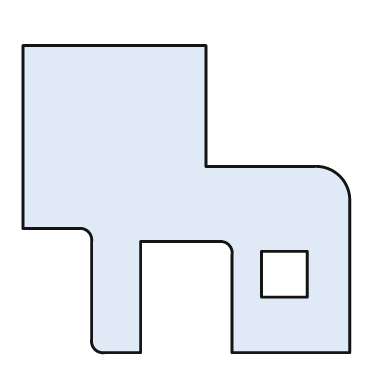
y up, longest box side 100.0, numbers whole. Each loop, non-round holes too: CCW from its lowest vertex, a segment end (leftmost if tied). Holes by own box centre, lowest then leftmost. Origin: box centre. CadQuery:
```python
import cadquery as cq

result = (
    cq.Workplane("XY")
    .moveTo(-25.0, -47.0)
    .lineTo(-14.0, -47.0)
    .lineTo(-14.0, -13.0)
    .lineTo(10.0, -13.0)
    .threePointArc((13.0, -14.0), (14.0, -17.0))
    .lineTo(14.0, -47.0)
    .lineTo(50.0, -47.0)
    .lineTo(50.0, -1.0)
    .threePointArc((47.0, 7.0), (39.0, 10.0))
    .lineTo(6.0, 10.0)
    .lineTo(6.0, 47.0)
    .lineTo(-50.0, 47.0)
    .lineTo(-50.0, -9.0)
    .lineTo(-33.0, -9.0)
    .threePointArc((-30.0, -10.0), (-29.0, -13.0))
    .lineTo(-29.0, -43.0)
    .threePointArc((-28.0, -46.0), (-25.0, -47.0))
    .close()
    .moveTo(23.0, -30.0)
    .lineTo(37.0, -30.0)
    .lineTo(37.0, -16.0)
    .lineTo(23.0, -16.0)
    .close()
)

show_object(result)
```